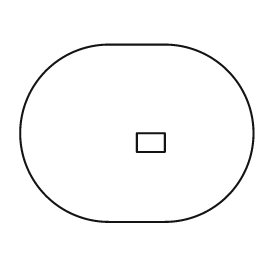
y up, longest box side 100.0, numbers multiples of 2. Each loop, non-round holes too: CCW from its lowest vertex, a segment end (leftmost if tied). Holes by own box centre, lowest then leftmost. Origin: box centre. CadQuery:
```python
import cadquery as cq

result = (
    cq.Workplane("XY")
    .moveTo(-12.0, -38.0)
    .lineTo(12.0, -38.0)
    .threePointArc((50.0, 0.0), (12.0, 38.0))
    .lineTo(-12.0, 38.0)
    .threePointArc((-50.0, 0.0), (-12.0, -38.0))
    .close()
    .moveTo(0.0, -8.0)
    .lineTo(12.0, -8.0)
    .lineTo(12.0, 0.0)
    .lineTo(0.0, 0.0)
    .close()
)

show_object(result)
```